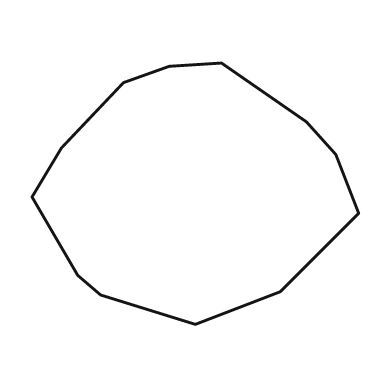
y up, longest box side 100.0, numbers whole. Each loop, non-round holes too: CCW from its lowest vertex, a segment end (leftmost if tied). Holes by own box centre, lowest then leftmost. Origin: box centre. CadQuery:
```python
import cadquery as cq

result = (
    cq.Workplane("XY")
    .moveTo(0.0, -40.0)
    .lineTo(26.0, -30.0)
    .lineTo(50.0, -6.0)
    .lineTo(43.0, 12.0)
    .lineTo(34.0, 22.0)
    .lineTo(8.0, 40.0)
    .lineTo(-8.0, 39.0)
    .lineTo(-22.0, 34.0)
    .lineTo(-41.0, 14.0)
    .lineTo(-50.0, -1.0)
    .lineTo(-36.0, -25.0)
    .lineTo(-29.0, -31.0)
    .close()
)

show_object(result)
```